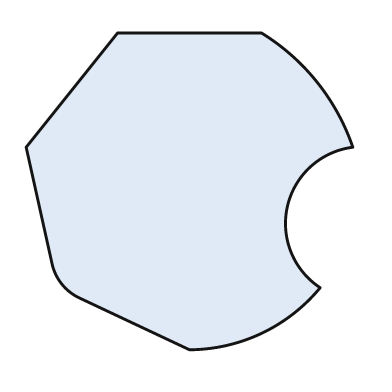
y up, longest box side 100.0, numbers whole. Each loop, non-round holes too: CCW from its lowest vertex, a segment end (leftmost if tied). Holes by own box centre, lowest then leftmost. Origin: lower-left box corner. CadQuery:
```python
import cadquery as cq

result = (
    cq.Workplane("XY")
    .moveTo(50.0, 0.0)
    .threePointArc((72.0, 5.0), (90.0, 19.0))
    .threePointArc((80.0, 44.0), (100.0, 62.0))
    .threePointArc((89.0, 82.0), (72.0, 97.0))
    .lineTo(28.0, 97.0)
    .lineTo(0.0, 62.0)
    .lineTo(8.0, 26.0)
    .threePointArc((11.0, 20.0), (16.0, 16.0))
    .close()
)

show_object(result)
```